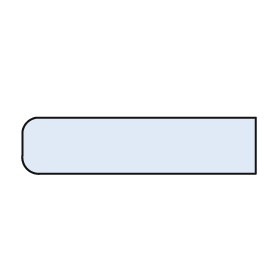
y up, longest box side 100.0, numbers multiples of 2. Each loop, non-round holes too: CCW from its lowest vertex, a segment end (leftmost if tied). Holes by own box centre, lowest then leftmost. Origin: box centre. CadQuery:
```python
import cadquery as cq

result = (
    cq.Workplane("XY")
    .moveTo(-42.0, -12.0)
    .lineTo(50.0, -12.0)
    .lineTo(50.0, 12.0)
    .lineTo(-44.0, 12.0)
    .threePointArc((-48.0, 10.0), (-50.0, 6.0))
    .lineTo(-50.0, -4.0)
    .threePointArc((-48.0, -10.0), (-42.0, -12.0))
    .close()
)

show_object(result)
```